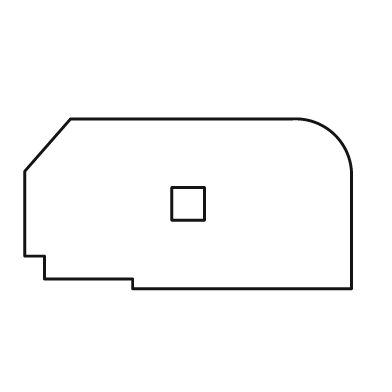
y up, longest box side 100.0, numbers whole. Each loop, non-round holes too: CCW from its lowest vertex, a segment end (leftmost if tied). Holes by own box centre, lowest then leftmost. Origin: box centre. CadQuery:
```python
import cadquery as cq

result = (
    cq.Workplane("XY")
    .moveTo(-17.0, -26.0)
    .lineTo(50.0, -26.0)
    .lineTo(50.0, 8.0)
    .threePointArc((45.0, 21.0), (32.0, 26.0))
    .lineTo(-36.0, 26.0)
    .lineTo(-50.0, 10.0)
    .lineTo(-50.0, -16.0)
    .lineTo(-44.0, -16.0)
    .lineTo(-44.0, -23.0)
    .lineTo(-17.0, -23.0)
    .close()
    .moveTo(-5.0, -5.0)
    .lineTo(5.0, -5.0)
    .lineTo(5.0, 5.0)
    .lineTo(-5.0, 5.0)
    .close()
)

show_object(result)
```